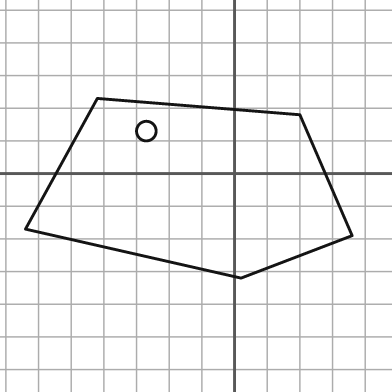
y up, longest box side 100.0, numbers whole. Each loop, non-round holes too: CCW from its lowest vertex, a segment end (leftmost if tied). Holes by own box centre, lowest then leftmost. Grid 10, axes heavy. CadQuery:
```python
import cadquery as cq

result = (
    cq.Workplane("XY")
    .moveTo(2.0, -32.0)
    .lineTo(36.0, -19.0)
    .lineTo(20.0, 18.0)
    .lineTo(-42.0, 23.0)
    .lineTo(-64.0, -17.0)
    .close()
    .moveTo(-27.0, 13.0)
    .circle(3.0)
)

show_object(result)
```